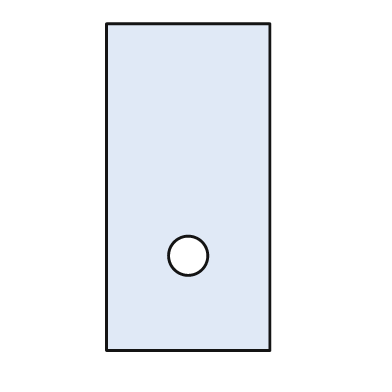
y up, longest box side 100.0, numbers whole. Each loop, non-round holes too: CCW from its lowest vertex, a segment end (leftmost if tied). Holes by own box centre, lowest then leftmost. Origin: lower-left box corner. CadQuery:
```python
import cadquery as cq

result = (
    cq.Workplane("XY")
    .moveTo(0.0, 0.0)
    .lineTo(50.0, 0.0)
    .lineTo(50.0, 100.0)
    .lineTo(0.0, 100.0)
    .close()
    .moveTo(25.0, 29.0)
    .circle(6.0)
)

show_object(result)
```